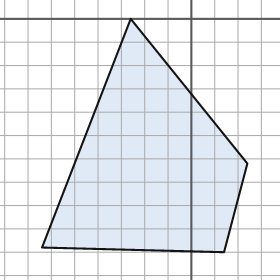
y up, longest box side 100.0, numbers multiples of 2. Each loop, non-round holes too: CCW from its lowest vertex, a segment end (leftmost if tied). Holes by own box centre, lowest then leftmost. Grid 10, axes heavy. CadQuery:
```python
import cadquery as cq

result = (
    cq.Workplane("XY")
    .moveTo(14.0, -100.0)
    .lineTo(24.0, -62.0)
    .lineTo(-26.0, 0.0)
    .lineTo(-64.0, -98.0)
    .close()
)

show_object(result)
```